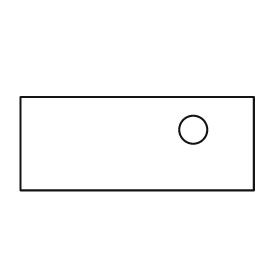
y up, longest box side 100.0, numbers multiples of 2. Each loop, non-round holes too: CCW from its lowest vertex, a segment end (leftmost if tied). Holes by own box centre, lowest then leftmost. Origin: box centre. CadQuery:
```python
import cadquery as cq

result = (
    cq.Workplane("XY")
    .moveTo(-50.0, -20.0)
    .lineTo(50.0, -20.0)
    .lineTo(50.0, 20.0)
    .lineTo(-50.0, 20.0)
    .close()
    .moveTo(24.0, 6.0)
    .circle(6.0)
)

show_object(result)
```